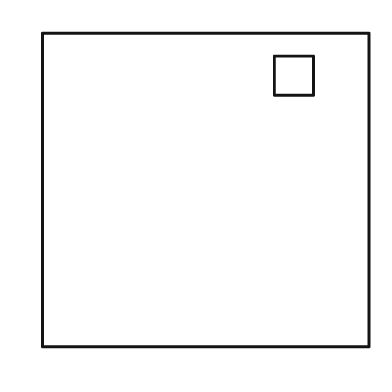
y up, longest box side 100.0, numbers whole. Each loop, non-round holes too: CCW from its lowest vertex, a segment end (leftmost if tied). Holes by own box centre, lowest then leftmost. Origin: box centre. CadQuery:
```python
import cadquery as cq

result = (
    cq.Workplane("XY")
    .moveTo(-50.0, -48.0)
    .lineTo(50.0, -48.0)
    .lineTo(50.0, 48.0)
    .lineTo(-50.0, 48.0)
    .close()
    .moveTo(21.0, 29.0)
    .lineTo(33.0, 29.0)
    .lineTo(33.0, 41.0)
    .lineTo(21.0, 41.0)
    .close()
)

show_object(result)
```